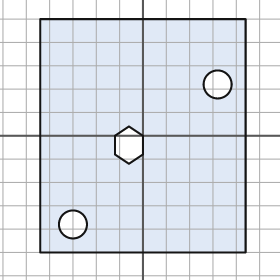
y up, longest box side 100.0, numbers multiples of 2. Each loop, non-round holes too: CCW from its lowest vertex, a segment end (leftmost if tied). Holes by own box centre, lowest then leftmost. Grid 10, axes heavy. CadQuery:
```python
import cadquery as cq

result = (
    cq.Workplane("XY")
    .moveTo(-44.0, -50.0)
    .lineTo(44.0, -50.0)
    .lineTo(44.0, 50.0)
    .lineTo(-44.0, 50.0)
    .close()
    .moveTo(-30.0, -38.0)
    .circle(6.0)
    .moveTo(-6.0, -12.0)
    .lineTo(0.0, -8.0)
    .lineTo(0.0, 0.0)
    .lineTo(-6.0, 4.0)
    .lineTo(-12.0, 0.0)
    .lineTo(-12.0, -8.0)
    .close()
    .moveTo(32.0, 22.0)
    .circle(6.0)
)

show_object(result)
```